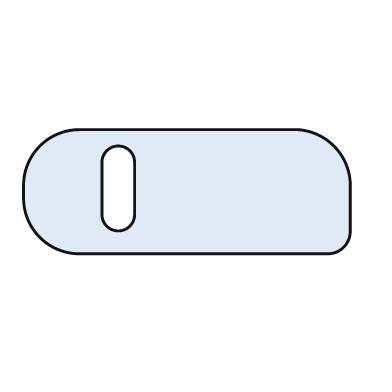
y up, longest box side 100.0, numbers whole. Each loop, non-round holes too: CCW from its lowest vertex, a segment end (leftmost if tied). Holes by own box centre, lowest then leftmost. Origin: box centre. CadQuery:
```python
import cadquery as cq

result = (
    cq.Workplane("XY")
    .moveTo(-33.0, -19.0)
    .lineTo(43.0, -19.0)
    .threePointArc((48.0, -17.0), (50.0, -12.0))
    .lineTo(50.0, 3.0)
    .threePointArc((45.0, 14.0), (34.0, 19.0))
    .lineTo(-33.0, 19.0)
    .threePointArc((-45.0, 14.0), (-50.0, 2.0))
    .lineTo(-50.0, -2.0)
    .threePointArc((-45.0, -14.0), (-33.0, -19.0))
    .close()
    .moveTo(-26.0, -7.0)
    .threePointArc((-21.0, -12.0), (-16.0, -7.0))
    .lineTo(-16.0, 9.0)
    .threePointArc((-21.0, 14.0), (-26.0, 9.0))
    .close()
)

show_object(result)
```